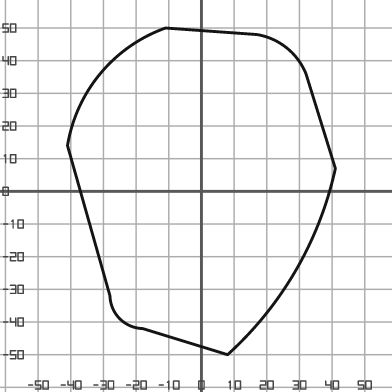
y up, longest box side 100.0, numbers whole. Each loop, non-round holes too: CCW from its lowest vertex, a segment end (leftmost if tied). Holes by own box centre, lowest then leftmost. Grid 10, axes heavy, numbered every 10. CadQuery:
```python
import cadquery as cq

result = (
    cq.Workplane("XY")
    .moveTo(8.0, -50.0)
    .threePointArc((29.0, -24.0), (41.0, 7.0))
    .lineTo(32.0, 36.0)
    .threePointArc((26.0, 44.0), (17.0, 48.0))
    .lineTo(-11.0, 50.0)
    .threePointArc((-31.0, 36.0), (-41.0, 14.0))
    .lineTo(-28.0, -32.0)
    .threePointArc((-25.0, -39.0), (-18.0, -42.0))
    .close()
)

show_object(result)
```